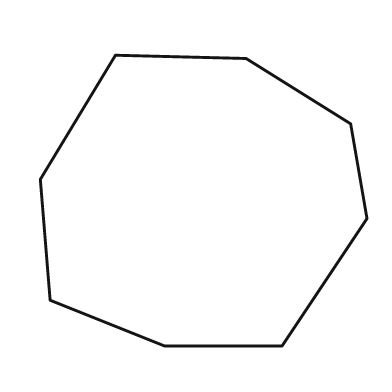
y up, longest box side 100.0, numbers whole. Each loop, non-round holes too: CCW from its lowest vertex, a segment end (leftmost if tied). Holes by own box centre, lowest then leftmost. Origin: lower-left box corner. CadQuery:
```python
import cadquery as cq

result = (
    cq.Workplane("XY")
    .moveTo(38.0, 0.0)
    .lineTo(74.0, 0.0)
    .lineTo(100.0, 39.0)
    .lineTo(95.0, 68.0)
    .lineTo(63.0, 88.0)
    .lineTo(23.0, 89.0)
    .lineTo(0.0, 51.0)
    .lineTo(3.0, 14.0)
    .close()
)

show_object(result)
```